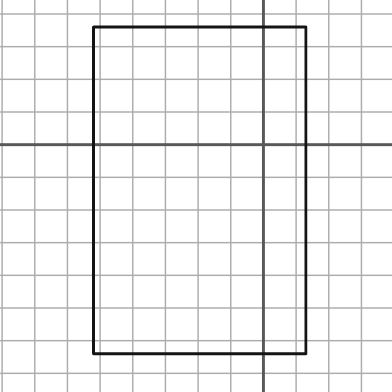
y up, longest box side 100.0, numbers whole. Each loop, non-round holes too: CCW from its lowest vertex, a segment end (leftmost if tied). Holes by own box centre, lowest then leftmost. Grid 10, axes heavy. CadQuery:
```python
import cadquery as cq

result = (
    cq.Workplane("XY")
    .moveTo(-52.0, -64.0)
    .lineTo(13.0, -64.0)
    .lineTo(13.0, 36.0)
    .lineTo(-52.0, 36.0)
    .close()
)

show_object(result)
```